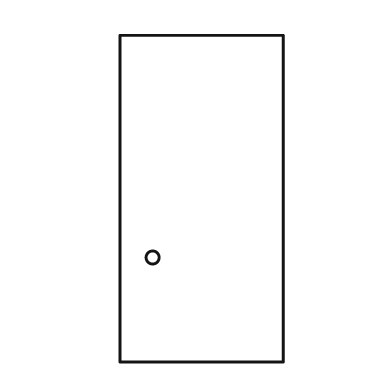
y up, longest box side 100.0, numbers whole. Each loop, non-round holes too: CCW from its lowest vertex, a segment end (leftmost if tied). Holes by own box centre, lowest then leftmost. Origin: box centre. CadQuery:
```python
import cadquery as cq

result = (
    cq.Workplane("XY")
    .moveTo(-25.0, -50.0)
    .lineTo(25.0, -50.0)
    .lineTo(25.0, 50.0)
    .lineTo(-25.0, 50.0)
    .close()
    .moveTo(-15.0, -18.0)
    .circle(2.0)
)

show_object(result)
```